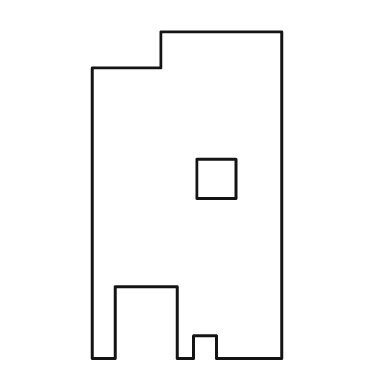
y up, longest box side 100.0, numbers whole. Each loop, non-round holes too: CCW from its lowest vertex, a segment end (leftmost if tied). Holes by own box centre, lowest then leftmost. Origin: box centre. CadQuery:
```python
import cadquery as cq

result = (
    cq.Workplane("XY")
    .moveTo(-29.0, -50.0)
    .lineTo(-22.0, -50.0)
    .lineTo(-22.0, -28.0)
    .lineTo(-3.0, -28.0)
    .lineTo(-3.0, -50.0)
    .lineTo(2.0, -50.0)
    .lineTo(2.0, -43.0)
    .lineTo(9.0, -43.0)
    .lineTo(9.0, -50.0)
    .lineTo(29.0, -50.0)
    .lineTo(29.0, 50.0)
    .lineTo(-8.0, 50.0)
    .lineTo(-8.0, 39.0)
    .lineTo(-29.0, 39.0)
    .close()
    .moveTo(3.0, -1.0)
    .lineTo(15.0, -1.0)
    .lineTo(15.0, 11.0)
    .lineTo(3.0, 11.0)
    .close()
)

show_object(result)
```